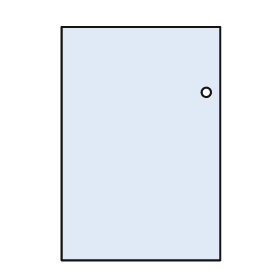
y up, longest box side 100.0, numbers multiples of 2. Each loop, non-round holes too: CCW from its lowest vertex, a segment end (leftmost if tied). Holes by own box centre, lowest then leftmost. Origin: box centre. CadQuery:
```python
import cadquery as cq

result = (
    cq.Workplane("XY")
    .moveTo(-34.0, -50.0)
    .lineTo(34.0, -50.0)
    .lineTo(34.0, 50.0)
    .lineTo(-34.0, 50.0)
    .close()
    .moveTo(28.0, 22.0)
    .circle(2.0)
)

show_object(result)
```